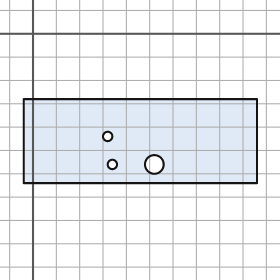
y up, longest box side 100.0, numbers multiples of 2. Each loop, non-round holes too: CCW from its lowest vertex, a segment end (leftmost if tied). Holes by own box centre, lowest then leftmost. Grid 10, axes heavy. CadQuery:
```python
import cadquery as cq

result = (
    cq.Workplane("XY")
    .moveTo(-4.0, -64.0)
    .lineTo(96.0, -64.0)
    .lineTo(96.0, -28.0)
    .lineTo(-4.0, -28.0)
    .close()
    .moveTo(34.0, -56.0)
    .circle(2.0)
    .moveTo(52.0, -56.0)
    .circle(4.0)
    .moveTo(32.0, -44.0)
    .circle(2.0)
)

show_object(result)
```